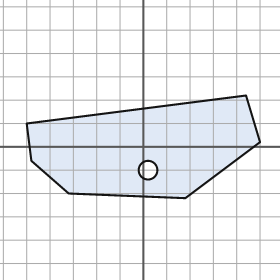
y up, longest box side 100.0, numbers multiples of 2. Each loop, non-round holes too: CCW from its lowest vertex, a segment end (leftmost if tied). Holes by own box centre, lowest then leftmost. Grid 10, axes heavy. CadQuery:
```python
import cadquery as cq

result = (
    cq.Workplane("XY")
    .moveTo(18.0, -22.0)
    .lineTo(50.0, 2.0)
    .lineTo(44.0, 22.0)
    .lineTo(-50.0, 10.0)
    .lineTo(-48.0, -6.0)
    .lineTo(-32.0, -20.0)
    .close()
    .moveTo(2.0, -10.0)
    .circle(4.0)
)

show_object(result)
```